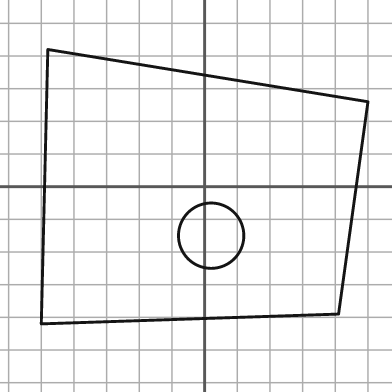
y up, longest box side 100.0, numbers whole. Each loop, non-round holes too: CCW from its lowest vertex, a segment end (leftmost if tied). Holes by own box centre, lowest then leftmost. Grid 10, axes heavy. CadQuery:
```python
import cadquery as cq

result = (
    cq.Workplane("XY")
    .moveTo(-50.0, -42.0)
    .lineTo(41.0, -39.0)
    .lineTo(50.0, 26.0)
    .lineTo(-48.0, 42.0)
    .close()
    .moveTo(2.0, -15.0)
    .circle(10.0)
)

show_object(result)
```